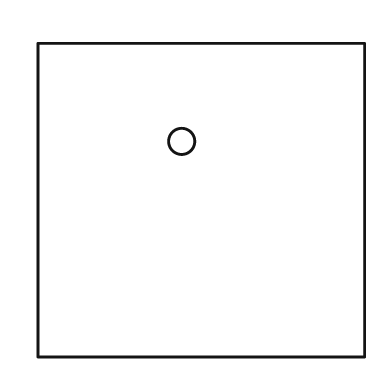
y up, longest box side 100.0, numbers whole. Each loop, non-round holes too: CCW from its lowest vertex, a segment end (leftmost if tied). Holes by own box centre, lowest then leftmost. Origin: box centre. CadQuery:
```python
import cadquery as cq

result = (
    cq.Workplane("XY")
    .moveTo(-50.0, -48.0)
    .lineTo(50.0, -48.0)
    .lineTo(50.0, 48.0)
    .lineTo(-50.0, 48.0)
    .close()
    .moveTo(-6.0, 18.0)
    .circle(4.0)
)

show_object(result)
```